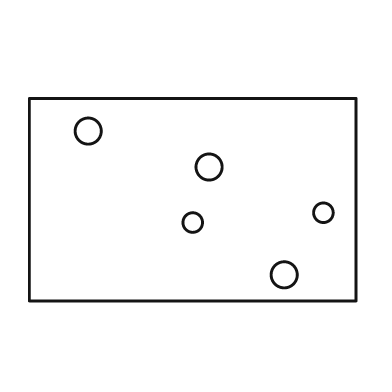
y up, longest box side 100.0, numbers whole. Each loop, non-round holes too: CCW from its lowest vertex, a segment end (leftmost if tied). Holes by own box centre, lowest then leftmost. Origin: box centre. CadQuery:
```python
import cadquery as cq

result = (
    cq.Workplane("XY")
    .moveTo(-50.0, -31.0)
    .lineTo(50.0, -31.0)
    .lineTo(50.0, 31.0)
    .lineTo(-50.0, 31.0)
    .close()
    .moveTo(28.0, -23.0)
    .circle(4.0)
    .moveTo(0.0, -7.0)
    .circle(3.0)
    .moveTo(40.0, -4.0)
    .circle(3.0)
    .moveTo(5.0, 10.0)
    .circle(4.0)
    .moveTo(-32.0, 21.0)
    .circle(4.0)
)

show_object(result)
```